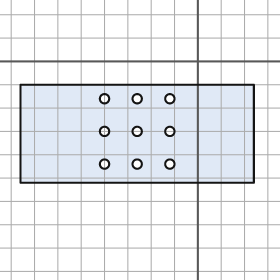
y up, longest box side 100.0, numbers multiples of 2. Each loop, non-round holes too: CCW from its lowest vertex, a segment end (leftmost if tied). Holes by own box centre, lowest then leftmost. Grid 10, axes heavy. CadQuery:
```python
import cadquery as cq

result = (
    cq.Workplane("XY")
    .moveTo(-76.0, -52.0)
    .lineTo(24.0, -52.0)
    .lineTo(24.0, -10.0)
    .lineTo(-76.0, -10.0)
    .close()
    .moveTo(-40.0, -44.0)
    .circle(2.0)
    .moveTo(-26.0, -44.0)
    .circle(2.0)
    .moveTo(-12.0, -44.0)
    .circle(2.0)
    .moveTo(-40.0, -30.0)
    .circle(2.0)
    .moveTo(-26.0, -30.0)
    .circle(2.0)
    .moveTo(-12.0, -30.0)
    .circle(2.0)
    .moveTo(-40.0, -16.0)
    .circle(2.0)
    .moveTo(-26.0, -16.0)
    .circle(2.0)
    .moveTo(-12.0, -16.0)
    .circle(2.0)
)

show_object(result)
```